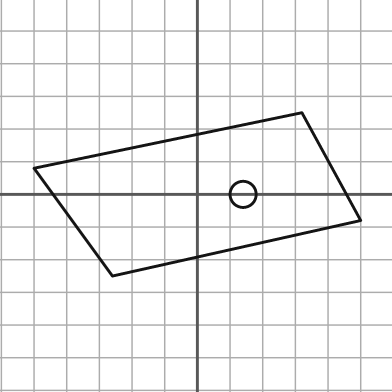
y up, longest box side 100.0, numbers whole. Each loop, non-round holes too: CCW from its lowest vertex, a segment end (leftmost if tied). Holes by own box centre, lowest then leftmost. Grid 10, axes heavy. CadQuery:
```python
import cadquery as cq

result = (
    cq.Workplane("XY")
    .moveTo(-26.0, -25.0)
    .lineTo(50.0, -8.0)
    .lineTo(32.0, 25.0)
    .lineTo(-50.0, 8.0)
    .close()
    .moveTo(14.0, 0.0)
    .circle(4.0)
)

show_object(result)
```